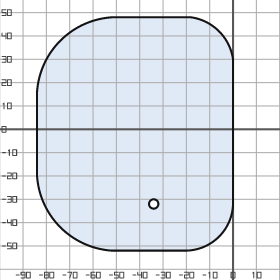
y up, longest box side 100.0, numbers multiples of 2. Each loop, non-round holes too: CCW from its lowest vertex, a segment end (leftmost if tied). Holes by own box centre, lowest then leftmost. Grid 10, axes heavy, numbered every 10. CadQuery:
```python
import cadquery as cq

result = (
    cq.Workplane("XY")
    .moveTo(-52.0, -52.0)
    .lineTo(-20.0, -52.0)
    .threePointArc((-6.0, -46.0), (0.0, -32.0))
    .lineTo(0.0, 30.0)
    .threePointArc((-6.0, 42.0), (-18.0, 48.0))
    .lineTo(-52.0, 48.0)
    .threePointArc((-74.0, 38.0), (-84.0, 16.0))
    .lineTo(-84.0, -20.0)
    .threePointArc((-74.0, -42.0), (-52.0, -52.0))
    .close()
    .moveTo(-34.0, -32.0)
    .circle(2.0)
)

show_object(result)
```